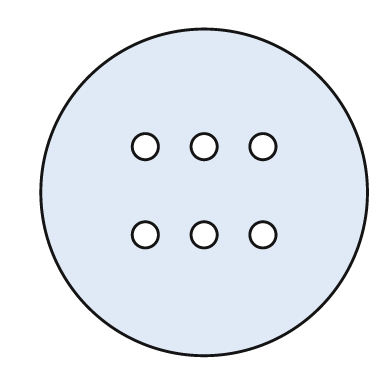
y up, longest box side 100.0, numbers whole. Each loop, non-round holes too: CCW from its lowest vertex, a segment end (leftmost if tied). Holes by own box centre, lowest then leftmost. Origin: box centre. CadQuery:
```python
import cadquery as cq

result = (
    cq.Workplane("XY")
    .moveTo(0.0, 0.0)
    .circle(50.0)
    .moveTo(-18.0, -13.0)
    .circle(4.0)
    .moveTo(0.0, -13.0)
    .circle(4.0)
    .moveTo(18.0, -13.0)
    .circle(4.0)
    .moveTo(-18.0, 14.0)
    .circle(4.0)
    .moveTo(0.0, 14.0)
    .circle(4.0)
    .moveTo(18.0, 14.0)
    .circle(4.0)
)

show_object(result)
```